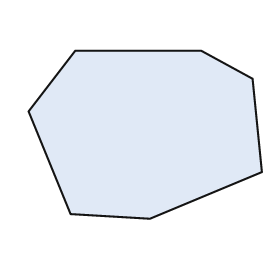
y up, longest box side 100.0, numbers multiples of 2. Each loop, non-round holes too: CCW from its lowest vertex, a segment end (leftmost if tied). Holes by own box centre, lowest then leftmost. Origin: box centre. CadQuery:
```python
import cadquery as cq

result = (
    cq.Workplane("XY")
    .moveTo(2.0, -36.0)
    .lineTo(50.0, -16.0)
    .lineTo(46.0, 24.0)
    .lineTo(24.0, 36.0)
    .lineTo(-30.0, 36.0)
    .lineTo(-50.0, 10.0)
    .lineTo(-32.0, -34.0)
    .close()
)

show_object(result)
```